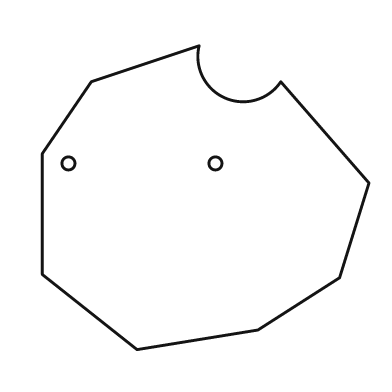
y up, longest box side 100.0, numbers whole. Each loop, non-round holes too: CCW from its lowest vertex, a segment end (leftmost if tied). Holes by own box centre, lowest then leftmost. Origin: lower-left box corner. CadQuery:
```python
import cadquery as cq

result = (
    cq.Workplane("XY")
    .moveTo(29.0, 0.0)
    .lineTo(66.0, 6.0)
    .lineTo(91.0, 22.0)
    .lineTo(100.0, 51.0)
    .lineTo(73.0, 82.0)
    .threePointArc((56.0, 77.0), (48.0, 93.0))
    .lineTo(15.0, 82.0)
    .lineTo(0.0, 60.0)
    .lineTo(0.0, 23.0)
    .close()
    .moveTo(8.0, 57.0)
    .circle(2.0)
    .moveTo(53.0, 57.0)
    .circle(2.0)
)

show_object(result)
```